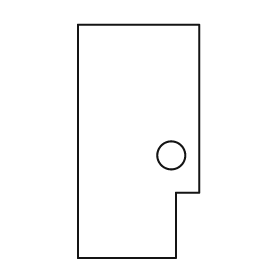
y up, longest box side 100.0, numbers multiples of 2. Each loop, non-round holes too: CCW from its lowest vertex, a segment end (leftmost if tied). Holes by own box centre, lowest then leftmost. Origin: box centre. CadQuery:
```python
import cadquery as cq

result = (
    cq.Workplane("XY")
    .moveTo(-26.0, -50.0)
    .lineTo(16.0, -50.0)
    .lineTo(16.0, -22.0)
    .lineTo(26.0, -22.0)
    .lineTo(26.0, 50.0)
    .lineTo(-26.0, 50.0)
    .close()
    .moveTo(14.0, -6.0)
    .circle(6.0)
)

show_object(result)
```